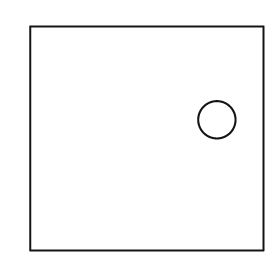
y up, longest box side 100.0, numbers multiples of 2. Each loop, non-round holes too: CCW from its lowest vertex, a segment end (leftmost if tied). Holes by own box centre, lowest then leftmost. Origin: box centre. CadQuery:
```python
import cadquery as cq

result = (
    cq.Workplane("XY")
    .moveTo(-50.0, -48.0)
    .lineTo(50.0, -48.0)
    .lineTo(50.0, 48.0)
    .lineTo(-50.0, 48.0)
    .close()
    .moveTo(30.0, 8.0)
    .circle(8.0)
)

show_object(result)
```